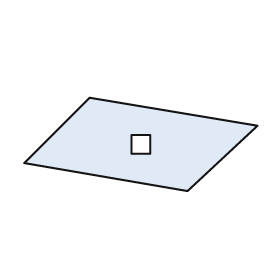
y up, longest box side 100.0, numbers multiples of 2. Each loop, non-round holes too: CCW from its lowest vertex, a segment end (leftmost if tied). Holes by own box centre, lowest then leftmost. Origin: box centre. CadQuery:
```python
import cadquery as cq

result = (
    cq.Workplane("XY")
    .moveTo(20.0, -20.0)
    .lineTo(50.0, 8.0)
    .lineTo(-22.0, 20.0)
    .lineTo(-50.0, -8.0)
    .close()
    .moveTo(-4.0, -4.0)
    .lineTo(4.0, -4.0)
    .lineTo(4.0, 4.0)
    .lineTo(-4.0, 4.0)
    .close()
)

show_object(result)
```